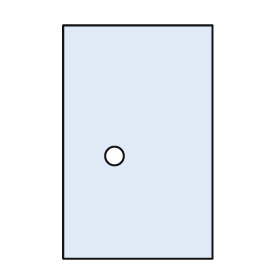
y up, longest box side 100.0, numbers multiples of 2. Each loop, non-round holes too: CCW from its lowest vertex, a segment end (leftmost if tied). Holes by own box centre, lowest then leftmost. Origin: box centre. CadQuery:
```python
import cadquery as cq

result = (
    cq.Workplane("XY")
    .moveTo(-32.0, -50.0)
    .lineTo(32.0, -50.0)
    .lineTo(32.0, 50.0)
    .lineTo(-32.0, 50.0)
    .close()
    .moveTo(-10.0, -6.0)
    .circle(4.0)
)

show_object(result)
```